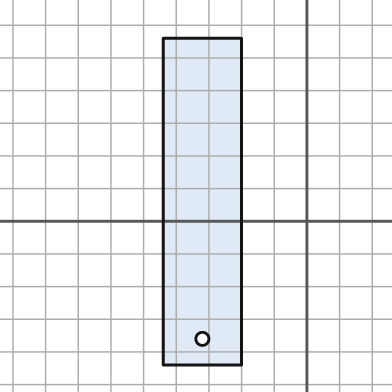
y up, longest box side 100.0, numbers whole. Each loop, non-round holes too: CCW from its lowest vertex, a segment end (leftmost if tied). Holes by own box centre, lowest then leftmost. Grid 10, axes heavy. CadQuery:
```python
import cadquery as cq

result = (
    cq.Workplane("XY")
    .moveTo(-44.0, -44.0)
    .lineTo(-20.0, -44.0)
    .lineTo(-20.0, 56.0)
    .lineTo(-44.0, 56.0)
    .close()
    .moveTo(-32.0, -36.0)
    .circle(2.0)
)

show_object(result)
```